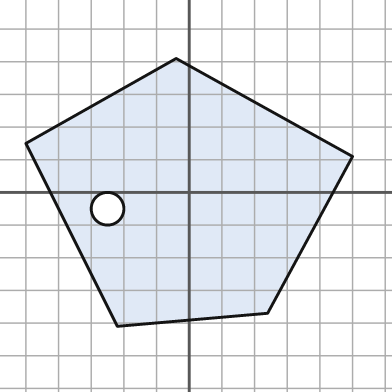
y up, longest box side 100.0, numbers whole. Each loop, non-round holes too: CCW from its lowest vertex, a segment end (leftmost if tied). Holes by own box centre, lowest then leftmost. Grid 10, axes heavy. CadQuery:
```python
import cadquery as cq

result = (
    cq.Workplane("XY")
    .moveTo(-22.0, -41.0)
    .lineTo(24.0, -37.0)
    .lineTo(50.0, 11.0)
    .lineTo(-4.0, 41.0)
    .lineTo(-50.0, 15.0)
    .close()
    .moveTo(-25.0, -5.0)
    .circle(5.0)
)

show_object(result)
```